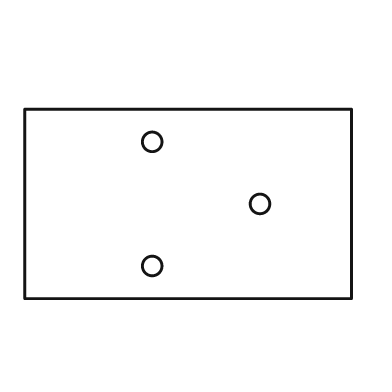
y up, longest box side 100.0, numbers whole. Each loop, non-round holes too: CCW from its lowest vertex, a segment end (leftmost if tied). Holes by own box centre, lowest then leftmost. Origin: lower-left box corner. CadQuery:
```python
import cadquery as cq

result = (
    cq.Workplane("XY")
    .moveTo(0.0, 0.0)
    .lineTo(100.0, 0.0)
    .lineTo(100.0, 58.0)
    .lineTo(0.0, 58.0)
    .close()
    .moveTo(39.0, 10.0)
    .circle(3.0)
    .moveTo(72.0, 29.0)
    .circle(3.0)
    .moveTo(39.0, 48.0)
    .circle(3.0)
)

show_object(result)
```